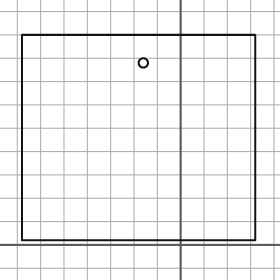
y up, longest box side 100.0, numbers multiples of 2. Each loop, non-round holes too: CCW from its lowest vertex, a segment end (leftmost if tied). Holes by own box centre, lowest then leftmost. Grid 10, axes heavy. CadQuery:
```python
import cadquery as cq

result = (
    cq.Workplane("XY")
    .moveTo(-68.0, 2.0)
    .lineTo(32.0, 2.0)
    .lineTo(32.0, 90.0)
    .lineTo(-68.0, 90.0)
    .close()
    .moveTo(-16.0, 78.0)
    .circle(2.0)
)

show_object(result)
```